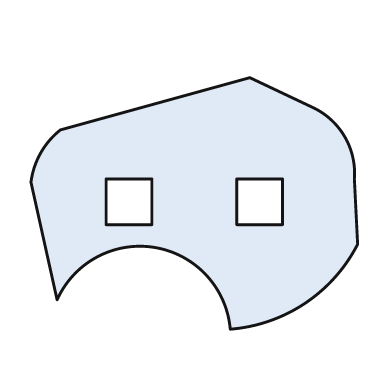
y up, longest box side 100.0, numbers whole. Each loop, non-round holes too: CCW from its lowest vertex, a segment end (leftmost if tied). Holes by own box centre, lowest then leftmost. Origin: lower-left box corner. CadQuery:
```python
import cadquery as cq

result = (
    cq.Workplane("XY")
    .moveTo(61.0, 0.0)
    .threePointArc((84.0, 8.0), (100.0, 26.0))
    .lineTo(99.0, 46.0)
    .threePointArc((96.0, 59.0), (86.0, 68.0))
    .lineTo(67.0, 77.0)
    .lineTo(9.0, 61.0)
    .threePointArc((3.0, 54.0), (0.0, 45.0))
    .lineTo(8.0, 9.0)
    .threePointArc((38.0, 25.0), (61.0, 0.0))
    .close()
    .moveTo(23.0, 32.0)
    .lineTo(37.0, 32.0)
    .lineTo(37.0, 46.0)
    .lineTo(23.0, 46.0)
    .close()
    .moveTo(63.0, 32.0)
    .lineTo(77.0, 32.0)
    .lineTo(77.0, 46.0)
    .lineTo(63.0, 46.0)
    .close()
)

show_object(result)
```